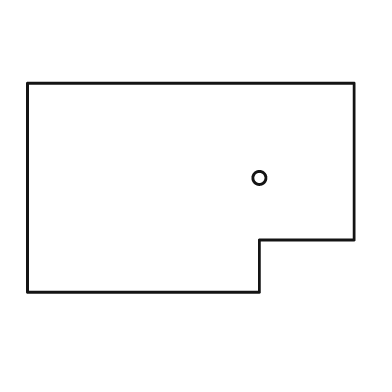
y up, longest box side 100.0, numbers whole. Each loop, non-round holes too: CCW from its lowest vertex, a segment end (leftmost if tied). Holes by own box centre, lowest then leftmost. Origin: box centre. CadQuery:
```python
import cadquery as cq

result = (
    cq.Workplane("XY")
    .moveTo(-50.0, -32.0)
    .lineTo(21.0, -32.0)
    .lineTo(21.0, -16.0)
    .lineTo(50.0, -16.0)
    .lineTo(50.0, 32.0)
    .lineTo(-50.0, 32.0)
    .close()
    .moveTo(21.0, 3.0)
    .circle(2.0)
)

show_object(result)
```